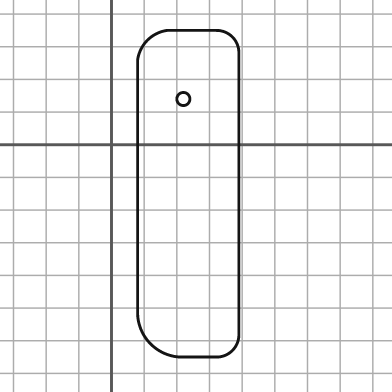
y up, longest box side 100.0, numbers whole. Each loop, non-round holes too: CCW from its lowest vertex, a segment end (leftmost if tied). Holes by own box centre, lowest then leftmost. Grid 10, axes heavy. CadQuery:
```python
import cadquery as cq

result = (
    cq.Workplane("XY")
    .moveTo(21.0, -65.0)
    .lineTo(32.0, -65.0)
    .threePointArc((37.0, -63.0), (39.0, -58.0))
    .lineTo(39.0, 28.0)
    .threePointArc((37.0, 33.0), (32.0, 35.0))
    .lineTo(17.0, 35.0)
    .threePointArc((11.0, 32.0), (8.0, 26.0))
    .lineTo(8.0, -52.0)
    .threePointArc((12.0, -61.0), (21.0, -65.0))
    .close()
    .moveTo(22.0, 14.0)
    .circle(2.0)
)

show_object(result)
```